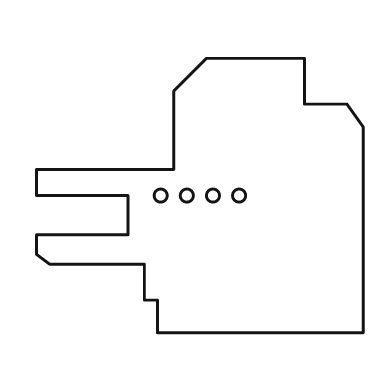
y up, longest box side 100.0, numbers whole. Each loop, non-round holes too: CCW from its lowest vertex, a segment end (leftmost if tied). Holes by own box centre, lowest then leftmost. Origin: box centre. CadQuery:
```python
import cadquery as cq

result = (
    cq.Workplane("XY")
    .moveTo(-13.0, -42.0)
    .lineTo(50.0, -42.0)
    .lineTo(50.0, 21.0)
    .lineTo(45.0, 28.0)
    .lineTo(32.0, 28.0)
    .lineTo(32.0, 42.0)
    .lineTo(2.0, 42.0)
    .lineTo(-8.0, 32.0)
    .lineTo(-8.0, 8.0)
    .lineTo(-50.0, 8.0)
    .lineTo(-50.0, 0.0)
    .lineTo(-22.0, 0.0)
    .lineTo(-22.0, -12.0)
    .lineTo(-50.0, -12.0)
    .lineTo(-50.0, -18.0)
    .lineTo(-46.0, -21.0)
    .lineTo(-17.0, -21.0)
    .lineTo(-17.0, -32.0)
    .lineTo(-13.0, -32.0)
    .close()
    .moveTo(-12.0, 0.0)
    .circle(2.0)
    .moveTo(-4.0, 0.0)
    .circle(2.0)
    .moveTo(4.0, 0.0)
    .circle(2.0)
    .moveTo(12.0, 0.0)
    .circle(2.0)
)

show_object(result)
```